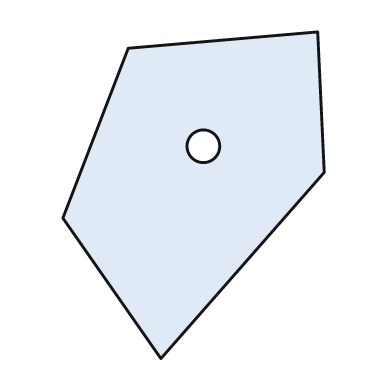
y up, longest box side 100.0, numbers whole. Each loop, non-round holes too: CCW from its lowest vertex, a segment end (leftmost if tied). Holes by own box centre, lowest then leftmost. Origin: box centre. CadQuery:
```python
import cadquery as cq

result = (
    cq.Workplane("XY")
    .moveTo(-10.0, -50.0)
    .lineTo(40.0, 7.0)
    .lineTo(38.0, 50.0)
    .lineTo(-20.0, 45.0)
    .lineTo(-40.0, -7.0)
    .close()
    .moveTo(3.0, 15.0)
    .circle(5.0)
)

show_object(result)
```